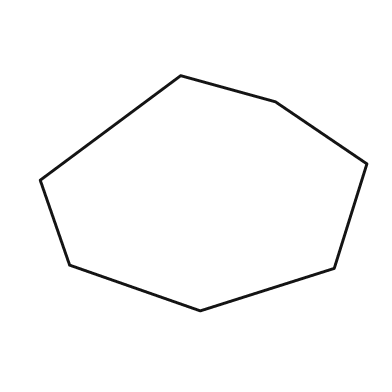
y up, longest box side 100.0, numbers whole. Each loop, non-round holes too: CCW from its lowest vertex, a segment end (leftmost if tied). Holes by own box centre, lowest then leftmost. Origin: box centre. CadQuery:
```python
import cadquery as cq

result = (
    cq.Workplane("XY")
    .moveTo(-1.0, -36.0)
    .lineTo(40.0, -23.0)
    .lineTo(50.0, 9.0)
    .lineTo(22.0, 28.0)
    .lineTo(-7.0, 36.0)
    .lineTo(-50.0, 4.0)
    .lineTo(-41.0, -22.0)
    .close()
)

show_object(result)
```